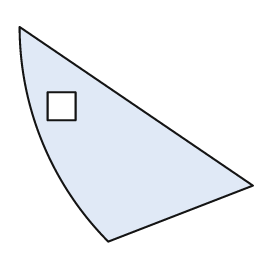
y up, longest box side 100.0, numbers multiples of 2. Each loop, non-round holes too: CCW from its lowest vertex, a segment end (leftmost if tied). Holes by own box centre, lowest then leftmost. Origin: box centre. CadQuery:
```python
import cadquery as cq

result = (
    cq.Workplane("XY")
    .moveTo(-12.0, -46.0)
    .lineTo(50.0, -22.0)
    .lineTo(-50.0, 46.0)
    .threePointArc((-40.0, -4.0), (-12.0, -46.0))
    .close()
    .moveTo(-38.0, 6.0)
    .lineTo(-26.0, 6.0)
    .lineTo(-26.0, 18.0)
    .lineTo(-38.0, 18.0)
    .close()
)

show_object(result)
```